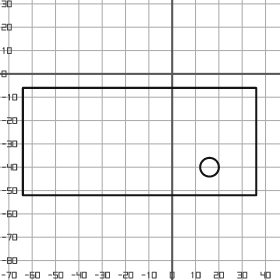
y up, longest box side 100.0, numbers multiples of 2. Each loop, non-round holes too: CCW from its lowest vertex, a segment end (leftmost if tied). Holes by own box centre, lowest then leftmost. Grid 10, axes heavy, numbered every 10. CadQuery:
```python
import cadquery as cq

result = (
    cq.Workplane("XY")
    .moveTo(-64.0, -52.0)
    .lineTo(36.0, -52.0)
    .lineTo(36.0, -6.0)
    .lineTo(-64.0, -6.0)
    .close()
    .moveTo(16.0, -40.0)
    .circle(4.0)
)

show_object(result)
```